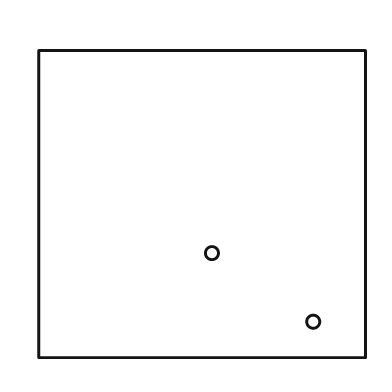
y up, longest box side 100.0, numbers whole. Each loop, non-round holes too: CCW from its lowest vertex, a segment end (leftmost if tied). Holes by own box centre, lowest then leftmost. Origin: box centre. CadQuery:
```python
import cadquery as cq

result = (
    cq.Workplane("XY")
    .moveTo(-50.0, -47.0)
    .lineTo(50.0, -47.0)
    .lineTo(50.0, 47.0)
    .lineTo(-50.0, 47.0)
    .close()
    .moveTo(34.0, -36.0)
    .circle(2.0)
    .moveTo(3.0, -15.0)
    .circle(2.0)
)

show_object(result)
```